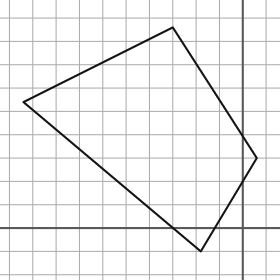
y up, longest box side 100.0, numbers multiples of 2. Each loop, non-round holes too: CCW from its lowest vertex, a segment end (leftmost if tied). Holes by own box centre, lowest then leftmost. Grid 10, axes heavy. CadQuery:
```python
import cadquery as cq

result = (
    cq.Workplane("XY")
    .moveTo(-18.0, -10.0)
    .lineTo(6.0, 30.0)
    .lineTo(-30.0, 86.0)
    .lineTo(-94.0, 54.0)
    .close()
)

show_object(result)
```